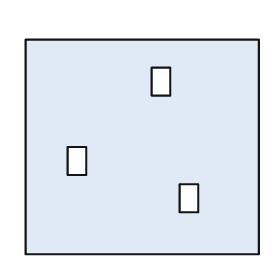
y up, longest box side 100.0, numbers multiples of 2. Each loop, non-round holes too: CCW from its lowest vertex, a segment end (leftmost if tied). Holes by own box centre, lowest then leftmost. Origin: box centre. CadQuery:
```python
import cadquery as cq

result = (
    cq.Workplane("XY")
    .moveTo(-50.0, -46.0)
    .lineTo(50.0, -46.0)
    .lineTo(50.0, 46.0)
    .lineTo(-50.0, 46.0)
    .close()
    .moveTo(16.0, -28.0)
    .lineTo(24.0, -28.0)
    .lineTo(24.0, -16.0)
    .lineTo(16.0, -16.0)
    .close()
    .moveTo(-32.0, -12.0)
    .lineTo(-24.0, -12.0)
    .lineTo(-24.0, 0.0)
    .lineTo(-32.0, 0.0)
    .close()
    .moveTo(4.0, 22.0)
    .lineTo(12.0, 22.0)
    .lineTo(12.0, 34.0)
    .lineTo(4.0, 34.0)
    .close()
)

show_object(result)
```